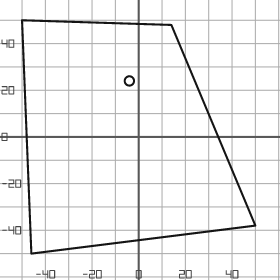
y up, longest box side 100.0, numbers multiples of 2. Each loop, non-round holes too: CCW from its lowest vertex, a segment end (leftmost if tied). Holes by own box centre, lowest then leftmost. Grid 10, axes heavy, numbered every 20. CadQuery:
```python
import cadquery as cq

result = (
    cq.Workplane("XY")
    .moveTo(-46.0, -50.0)
    .lineTo(50.0, -38.0)
    .lineTo(14.0, 48.0)
    .lineTo(-50.0, 50.0)
    .close()
    .moveTo(-4.0, 24.0)
    .circle(2.0)
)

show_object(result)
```